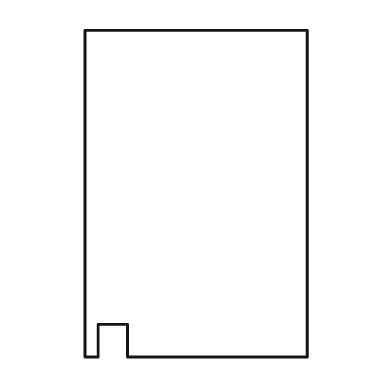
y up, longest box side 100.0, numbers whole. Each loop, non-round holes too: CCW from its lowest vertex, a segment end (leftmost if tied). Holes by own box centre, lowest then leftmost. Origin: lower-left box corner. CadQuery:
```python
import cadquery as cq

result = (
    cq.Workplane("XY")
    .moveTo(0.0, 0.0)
    .lineTo(4.0, 0.0)
    .lineTo(4.0, 10.0)
    .lineTo(13.0, 10.0)
    .lineTo(13.0, 0.0)
    .lineTo(68.0, 0.0)
    .lineTo(68.0, 100.0)
    .lineTo(0.0, 100.0)
    .close()
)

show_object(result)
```